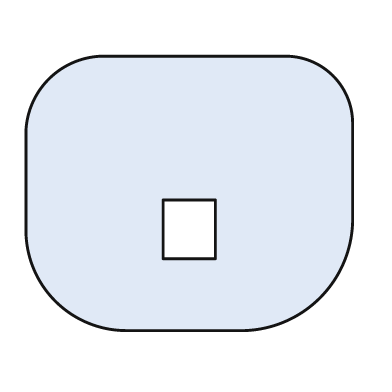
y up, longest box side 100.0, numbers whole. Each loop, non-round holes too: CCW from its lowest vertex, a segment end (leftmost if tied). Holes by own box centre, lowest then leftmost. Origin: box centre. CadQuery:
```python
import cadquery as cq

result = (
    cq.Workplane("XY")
    .moveTo(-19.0, -42.0)
    .lineTo(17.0, -42.0)
    .threePointArc((40.0, -32.0), (50.0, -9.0))
    .lineTo(50.0, 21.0)
    .threePointArc((44.0, 36.0), (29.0, 42.0))
    .lineTo(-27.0, 42.0)
    .threePointArc((-43.0, 35.0), (-50.0, 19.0))
    .lineTo(-50.0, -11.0)
    .threePointArc((-41.0, -33.0), (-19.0, -42.0))
    .close()
    .moveTo(-8.0, -20.0)
    .lineTo(8.0, -20.0)
    .lineTo(8.0, -2.0)
    .lineTo(-8.0, -2.0)
    .close()
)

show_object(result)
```